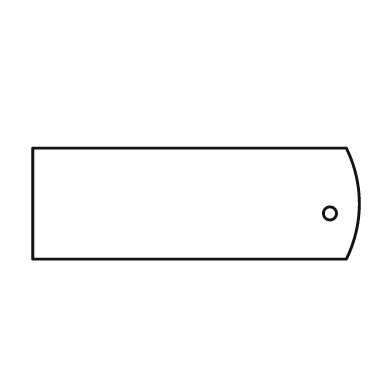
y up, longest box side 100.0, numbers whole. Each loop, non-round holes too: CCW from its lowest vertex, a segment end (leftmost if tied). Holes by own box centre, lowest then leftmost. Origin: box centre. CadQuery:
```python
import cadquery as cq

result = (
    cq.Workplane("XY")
    .moveTo(-50.0, -17.0)
    .lineTo(46.0, -17.0)
    .threePointArc((50.0, 0.0), (46.0, 17.0))
    .lineTo(-50.0, 17.0)
    .close()
    .moveTo(41.0, -3.0)
    .circle(2.0)
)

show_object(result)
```